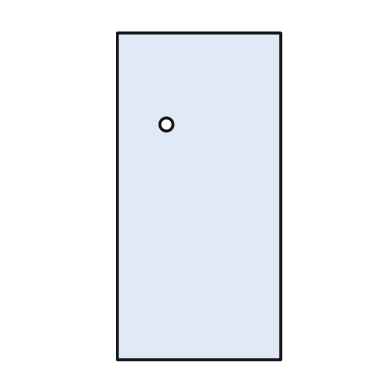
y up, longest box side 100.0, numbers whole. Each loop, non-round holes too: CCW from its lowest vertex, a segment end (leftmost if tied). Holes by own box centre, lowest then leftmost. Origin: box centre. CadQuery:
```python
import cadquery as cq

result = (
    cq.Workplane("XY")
    .moveTo(-25.0, -50.0)
    .lineTo(25.0, -50.0)
    .lineTo(25.0, 50.0)
    .lineTo(-25.0, 50.0)
    .close()
    .moveTo(-10.0, 22.0)
    .circle(2.0)
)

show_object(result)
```